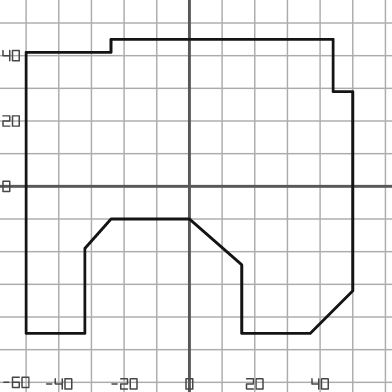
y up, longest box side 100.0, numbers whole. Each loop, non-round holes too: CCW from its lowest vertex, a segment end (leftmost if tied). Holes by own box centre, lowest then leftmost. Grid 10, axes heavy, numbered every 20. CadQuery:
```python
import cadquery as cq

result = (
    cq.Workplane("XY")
    .moveTo(-50.0, -45.0)
    .lineTo(-32.0, -45.0)
    .lineTo(-32.0, -19.0)
    .lineTo(-24.0, -10.0)
    .lineTo(0.0, -10.0)
    .lineTo(16.0, -24.0)
    .lineTo(16.0, -45.0)
    .lineTo(37.0, -45.0)
    .lineTo(50.0, -32.0)
    .lineTo(50.0, 29.0)
    .lineTo(44.0, 29.0)
    .lineTo(44.0, 45.0)
    .lineTo(-24.0, 45.0)
    .lineTo(-24.0, 41.0)
    .lineTo(-50.0, 41.0)
    .close()
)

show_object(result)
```